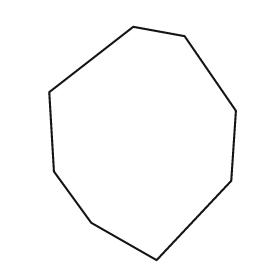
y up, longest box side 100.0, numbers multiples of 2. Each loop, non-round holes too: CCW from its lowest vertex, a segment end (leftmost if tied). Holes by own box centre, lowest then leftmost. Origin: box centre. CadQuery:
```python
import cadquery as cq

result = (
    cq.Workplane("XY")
    .moveTo(6.0, -50.0)
    .lineTo(38.0, -16.0)
    .lineTo(40.0, 14.0)
    .lineTo(18.0, 46.0)
    .lineTo(-4.0, 50.0)
    .lineTo(-40.0, 22.0)
    .lineTo(-38.0, -12.0)
    .lineTo(-22.0, -34.0)
    .close()
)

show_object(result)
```